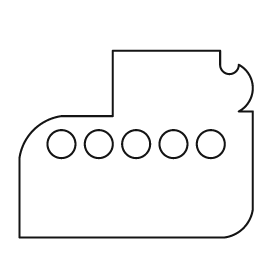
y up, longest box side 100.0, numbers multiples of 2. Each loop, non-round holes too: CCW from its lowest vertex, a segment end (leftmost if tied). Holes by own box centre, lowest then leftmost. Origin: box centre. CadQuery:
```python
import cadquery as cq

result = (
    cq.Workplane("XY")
    .moveTo(-50.0, -40.0)
    .lineTo(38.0, -40.0)
    .threePointArc((46.0, -36.0), (50.0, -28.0))
    .lineTo(50.0, 14.0)
    .lineTo(44.0, 14.0)
    .threePointArc((50.0, 24.0), (44.0, 34.0))
    .threePointArc((40.0, 30.0), (36.0, 34.0))
    .lineTo(36.0, 40.0)
    .lineTo(-10.0, 40.0)
    .lineTo(-10.0, 12.0)
    .lineTo(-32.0, 12.0)
    .threePointArc((-44.0, 6.0), (-50.0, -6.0))
    .close()
    .moveTo(-32.0, 0.0)
    .circle(6.0)
    .moveTo(-16.0, 0.0)
    .circle(6.0)
    .moveTo(0.0, 0.0)
    .circle(6.0)
    .moveTo(16.0, 0.0)
    .circle(6.0)
    .moveTo(32.0, 0.0)
    .circle(6.0)
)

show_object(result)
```